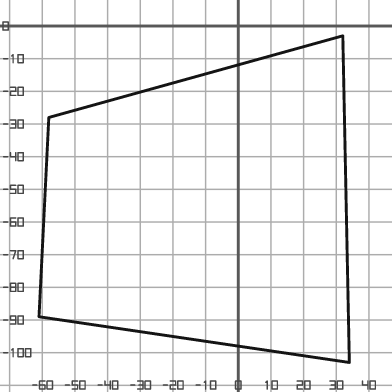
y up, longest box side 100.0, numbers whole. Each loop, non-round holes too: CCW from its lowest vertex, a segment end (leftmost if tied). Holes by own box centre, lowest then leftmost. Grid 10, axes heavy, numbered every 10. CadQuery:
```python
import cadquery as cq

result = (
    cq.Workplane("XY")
    .moveTo(34.0, -103.0)
    .lineTo(32.0, -3.0)
    .lineTo(-58.0, -28.0)
    .lineTo(-61.0, -89.0)
    .close()
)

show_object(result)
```